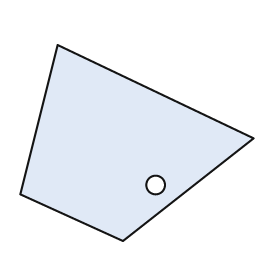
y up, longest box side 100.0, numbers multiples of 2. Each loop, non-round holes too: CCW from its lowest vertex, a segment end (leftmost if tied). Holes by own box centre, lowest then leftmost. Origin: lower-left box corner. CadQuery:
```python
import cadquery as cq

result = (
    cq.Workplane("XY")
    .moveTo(44.0, 0.0)
    .lineTo(100.0, 44.0)
    .lineTo(16.0, 84.0)
    .lineTo(0.0, 20.0)
    .close()
    .moveTo(58.0, 24.0)
    .circle(4.0)
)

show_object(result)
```